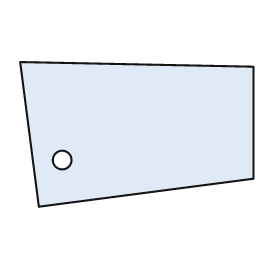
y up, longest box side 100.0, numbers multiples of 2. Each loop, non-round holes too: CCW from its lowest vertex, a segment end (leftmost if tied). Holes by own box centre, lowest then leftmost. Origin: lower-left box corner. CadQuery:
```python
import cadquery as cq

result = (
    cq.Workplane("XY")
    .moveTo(8.0, 0.0)
    .lineTo(100.0, 12.0)
    .lineTo(100.0, 60.0)
    .lineTo(0.0, 62.0)
    .close()
    .moveTo(18.0, 20.0)
    .circle(4.0)
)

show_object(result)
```